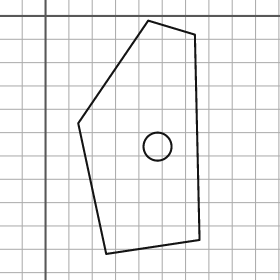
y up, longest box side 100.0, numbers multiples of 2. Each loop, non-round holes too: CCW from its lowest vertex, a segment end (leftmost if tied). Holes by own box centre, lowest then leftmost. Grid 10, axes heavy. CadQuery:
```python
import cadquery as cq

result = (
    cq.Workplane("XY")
    .moveTo(26.0, -102.0)
    .lineTo(66.0, -96.0)
    .lineTo(64.0, -8.0)
    .lineTo(44.0, -2.0)
    .lineTo(14.0, -46.0)
    .close()
    .moveTo(48.0, -56.0)
    .circle(6.0)
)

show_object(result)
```